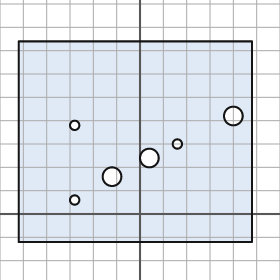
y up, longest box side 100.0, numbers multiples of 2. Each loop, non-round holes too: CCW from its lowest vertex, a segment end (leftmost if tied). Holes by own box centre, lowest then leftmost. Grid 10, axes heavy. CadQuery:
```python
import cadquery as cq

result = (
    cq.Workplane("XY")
    .moveTo(-52.0, -12.0)
    .lineTo(48.0, -12.0)
    .lineTo(48.0, 74.0)
    .lineTo(-52.0, 74.0)
    .close()
    .moveTo(-28.0, 6.0)
    .circle(2.0)
    .moveTo(-12.0, 16.0)
    .circle(4.0)
    .moveTo(4.0, 24.0)
    .circle(4.0)
    .moveTo(16.0, 30.0)
    .circle(2.0)
    .moveTo(-28.0, 38.0)
    .circle(2.0)
    .moveTo(40.0, 42.0)
    .circle(4.0)
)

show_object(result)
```